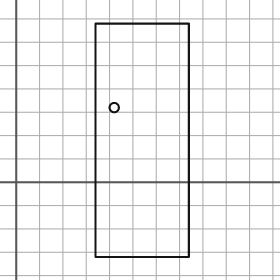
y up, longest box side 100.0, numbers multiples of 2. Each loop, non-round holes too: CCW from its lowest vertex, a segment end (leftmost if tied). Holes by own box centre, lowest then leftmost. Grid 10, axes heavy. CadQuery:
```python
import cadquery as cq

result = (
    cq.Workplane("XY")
    .moveTo(34.0, -32.0)
    .lineTo(74.0, -32.0)
    .lineTo(74.0, 68.0)
    .lineTo(34.0, 68.0)
    .close()
    .moveTo(42.0, 32.0)
    .circle(2.0)
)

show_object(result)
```